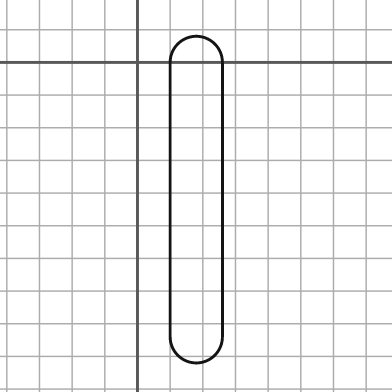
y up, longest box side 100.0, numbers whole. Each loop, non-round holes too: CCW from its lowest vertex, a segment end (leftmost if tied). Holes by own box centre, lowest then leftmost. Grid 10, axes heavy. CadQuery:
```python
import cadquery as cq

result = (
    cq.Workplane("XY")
    .moveTo(10.0, -84.0)
    .threePointArc((18.0, -92.0), (26.0, -84.0))
    .lineTo(26.0, 0.0)
    .threePointArc((18.0, 8.0), (10.0, 0.0))
    .close()
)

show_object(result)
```